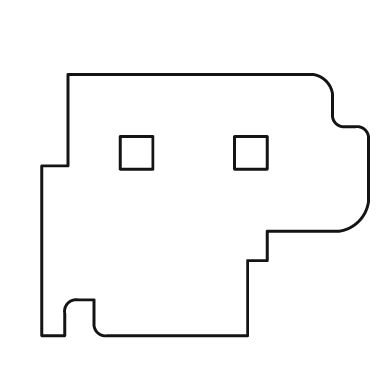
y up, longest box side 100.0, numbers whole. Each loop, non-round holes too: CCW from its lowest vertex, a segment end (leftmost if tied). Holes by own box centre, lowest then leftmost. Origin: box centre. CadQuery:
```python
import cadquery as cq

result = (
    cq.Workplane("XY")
    .moveTo(-50.0, -40.0)
    .lineTo(-43.0, -40.0)
    .lineTo(-43.0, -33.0)
    .threePointArc((-42.0, -30.0), (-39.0, -29.0))
    .lineTo(-34.0, -29.0)
    .lineTo(-34.0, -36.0)
    .threePointArc((-33.0, -39.0), (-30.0, -40.0))
    .lineTo(13.0, -40.0)
    .lineTo(13.0, -17.0)
    .lineTo(19.0, -17.0)
    .lineTo(19.0, -8.0)
    .lineTo(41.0, -8.0)
    .threePointArc((47.0, -5.0), (50.0, 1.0))
    .lineTo(50.0, 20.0)
    .threePointArc((49.0, 23.0), (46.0, 24.0))
    .lineTo(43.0, 24.0)
    .threePointArc((40.0, 25.0), (39.0, 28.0))
    .lineTo(39.0, 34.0)
    .threePointArc((37.0, 38.0), (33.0, 40.0))
    .lineTo(-42.0, 40.0)
    .lineTo(-42.0, 12.0)
    .lineTo(-50.0, 12.0)
    .close()
    .moveTo(-26.0, 11.0)
    .lineTo(-16.0, 11.0)
    .lineTo(-16.0, 21.0)
    .lineTo(-26.0, 21.0)
    .close()
    .moveTo(9.0, 11.0)
    .lineTo(19.0, 11.0)
    .lineTo(19.0, 21.0)
    .lineTo(9.0, 21.0)
    .close()
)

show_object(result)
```